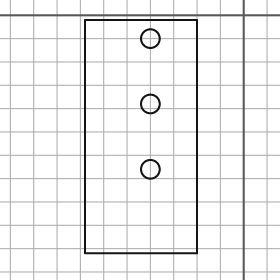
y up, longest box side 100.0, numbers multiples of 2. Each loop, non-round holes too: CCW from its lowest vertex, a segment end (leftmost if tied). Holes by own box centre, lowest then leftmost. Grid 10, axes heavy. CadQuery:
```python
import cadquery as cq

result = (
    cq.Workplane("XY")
    .moveTo(-68.0, -102.0)
    .lineTo(-20.0, -102.0)
    .lineTo(-20.0, -2.0)
    .lineTo(-68.0, -2.0)
    .close()
    .moveTo(-40.0, -66.0)
    .circle(4.0)
    .moveTo(-40.0, -38.0)
    .circle(4.0)
    .moveTo(-40.0, -10.0)
    .circle(4.0)
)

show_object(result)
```